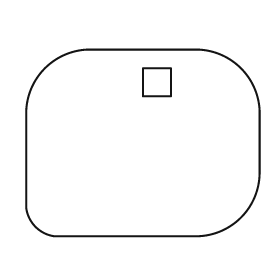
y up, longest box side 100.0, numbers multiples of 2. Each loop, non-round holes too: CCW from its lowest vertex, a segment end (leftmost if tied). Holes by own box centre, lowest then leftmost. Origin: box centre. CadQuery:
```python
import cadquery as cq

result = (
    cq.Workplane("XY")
    .moveTo(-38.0, -40.0)
    .lineTo(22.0, -40.0)
    .threePointArc((42.0, -32.0), (50.0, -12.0))
    .lineTo(50.0, 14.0)
    .threePointArc((42.0, 32.0), (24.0, 40.0))
    .lineTo(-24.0, 40.0)
    .threePointArc((-42.0, 32.0), (-50.0, 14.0))
    .lineTo(-50.0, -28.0)
    .threePointArc((-46.0, -36.0), (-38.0, -40.0))
    .close()
    .moveTo(0.0, 20.0)
    .lineTo(12.0, 20.0)
    .lineTo(12.0, 32.0)
    .lineTo(0.0, 32.0)
    .close()
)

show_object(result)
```